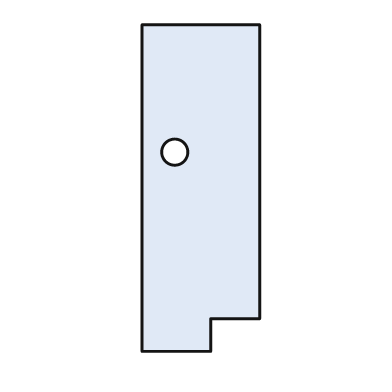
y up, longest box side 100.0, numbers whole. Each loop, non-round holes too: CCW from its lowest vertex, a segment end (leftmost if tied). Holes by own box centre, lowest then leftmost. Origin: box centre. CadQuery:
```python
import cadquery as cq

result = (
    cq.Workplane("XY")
    .moveTo(-18.0, -50.0)
    .lineTo(3.0, -50.0)
    .lineTo(3.0, -40.0)
    .lineTo(18.0, -40.0)
    .lineTo(18.0, 50.0)
    .lineTo(-18.0, 50.0)
    .close()
    .moveTo(-8.0, 11.0)
    .circle(4.0)
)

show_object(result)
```